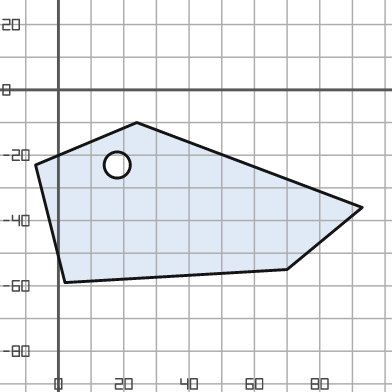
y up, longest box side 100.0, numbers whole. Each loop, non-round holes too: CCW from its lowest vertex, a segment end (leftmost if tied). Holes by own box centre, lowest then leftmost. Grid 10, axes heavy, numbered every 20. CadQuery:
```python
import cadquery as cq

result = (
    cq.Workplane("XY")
    .moveTo(2.0, -59.0)
    .lineTo(70.0, -55.0)
    .lineTo(93.0, -36.0)
    .lineTo(24.0, -10.0)
    .lineTo(-7.0, -23.0)
    .close()
    .moveTo(18.0, -23.0)
    .circle(4.0)
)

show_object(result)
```